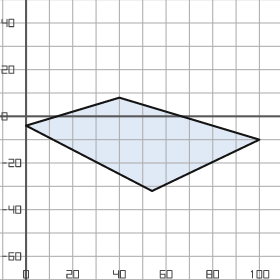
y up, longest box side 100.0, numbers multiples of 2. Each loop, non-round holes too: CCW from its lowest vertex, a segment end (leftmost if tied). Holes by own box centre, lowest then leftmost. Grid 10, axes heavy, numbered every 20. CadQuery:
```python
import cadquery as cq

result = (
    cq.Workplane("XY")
    .moveTo(54.0, -32.0)
    .lineTo(100.0, -10.0)
    .lineTo(40.0, 8.0)
    .lineTo(0.0, -4.0)
    .close()
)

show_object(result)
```